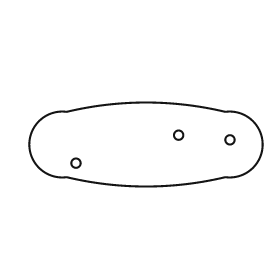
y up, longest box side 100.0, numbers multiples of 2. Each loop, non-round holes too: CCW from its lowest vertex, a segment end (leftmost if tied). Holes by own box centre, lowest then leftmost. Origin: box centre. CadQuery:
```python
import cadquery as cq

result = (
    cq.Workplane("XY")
    .moveTo(-34.0, -14.0)
    .threePointArc((0.0, -18.0), (34.0, -14.0))
    .threePointArc((50.0, 0.0), (34.0, 14.0))
    .threePointArc((0.0, 18.0), (-34.0, 14.0))
    .threePointArc((-50.0, 0.0), (-34.0, -14.0))
    .close()
    .moveTo(-30.0, -8.0)
    .circle(2.0)
    .moveTo(36.0, 2.0)
    .circle(2.0)
    .moveTo(14.0, 4.0)
    .circle(2.0)
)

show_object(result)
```